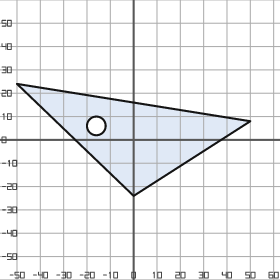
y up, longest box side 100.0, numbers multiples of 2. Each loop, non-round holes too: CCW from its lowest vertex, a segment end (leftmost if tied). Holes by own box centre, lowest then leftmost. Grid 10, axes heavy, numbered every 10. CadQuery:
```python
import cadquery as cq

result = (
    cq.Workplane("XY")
    .moveTo(0.0, -24.0)
    .lineTo(50.0, 8.0)
    .lineTo(-50.0, 24.0)
    .close()
    .moveTo(-16.0, 6.0)
    .circle(4.0)
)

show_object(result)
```